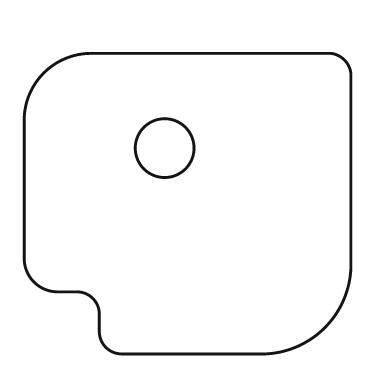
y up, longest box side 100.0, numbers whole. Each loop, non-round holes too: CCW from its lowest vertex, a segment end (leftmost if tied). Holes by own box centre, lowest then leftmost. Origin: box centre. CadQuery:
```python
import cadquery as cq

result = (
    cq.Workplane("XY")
    .moveTo(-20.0, -46.0)
    .lineTo(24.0, -46.0)
    .threePointArc((42.0, -38.0), (50.0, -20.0))
    .lineTo(50.0, 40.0)
    .threePointArc((48.0, 44.0), (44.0, 46.0))
    .lineTo(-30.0, 46.0)
    .threePointArc((-44.0, 40.0), (-50.0, 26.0))
    .lineTo(-50.0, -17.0)
    .threePointArc((-47.0, -24.0), (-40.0, -27.0))
    .lineTo(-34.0, -27.0)
    .threePointArc((-29.0, -29.0), (-27.0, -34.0))
    .lineTo(-27.0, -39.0)
    .threePointArc((-25.0, -44.0), (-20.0, -46.0))
    .close()
    .moveTo(-7.0, 17.0)
    .circle(9.0)
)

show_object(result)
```